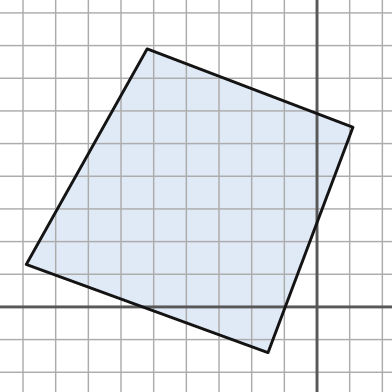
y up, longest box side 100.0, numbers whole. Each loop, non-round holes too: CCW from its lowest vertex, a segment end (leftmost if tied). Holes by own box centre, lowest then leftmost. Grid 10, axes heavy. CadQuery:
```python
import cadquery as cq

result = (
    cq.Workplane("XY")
    .moveTo(-15.0, -14.0)
    .lineTo(11.0, 55.0)
    .lineTo(-52.0, 79.0)
    .lineTo(-89.0, 13.0)
    .close()
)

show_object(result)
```